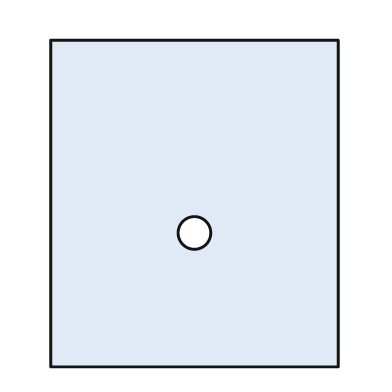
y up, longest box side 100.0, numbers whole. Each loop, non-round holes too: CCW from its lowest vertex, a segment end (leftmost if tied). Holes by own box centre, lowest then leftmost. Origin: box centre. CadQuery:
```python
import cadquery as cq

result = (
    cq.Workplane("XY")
    .moveTo(-44.0, -50.0)
    .lineTo(44.0, -50.0)
    .lineTo(44.0, 50.0)
    .lineTo(-44.0, 50.0)
    .close()
    .moveTo(0.0, -9.0)
    .circle(5.0)
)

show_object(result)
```